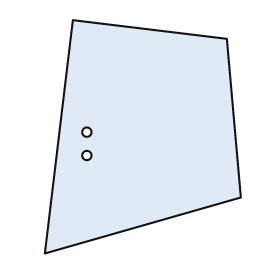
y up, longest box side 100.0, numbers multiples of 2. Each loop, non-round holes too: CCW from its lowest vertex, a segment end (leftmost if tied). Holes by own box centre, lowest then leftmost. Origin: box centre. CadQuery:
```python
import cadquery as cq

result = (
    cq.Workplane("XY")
    .moveTo(-42.0, -50.0)
    .lineTo(42.0, -26.0)
    .lineTo(36.0, 42.0)
    .lineTo(-30.0, 50.0)
    .close()
    .moveTo(-24.0, -8.0)
    .circle(2.0)
    .moveTo(-24.0, 2.0)
    .circle(2.0)
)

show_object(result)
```